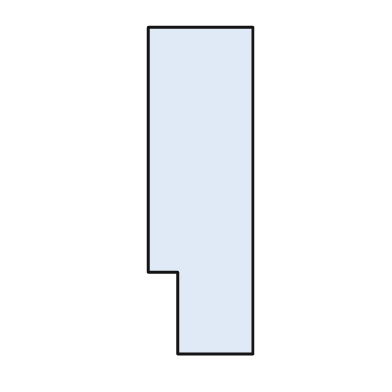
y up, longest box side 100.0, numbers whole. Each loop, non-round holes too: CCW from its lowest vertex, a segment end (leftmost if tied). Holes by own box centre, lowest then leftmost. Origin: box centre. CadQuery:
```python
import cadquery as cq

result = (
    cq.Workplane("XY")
    .moveTo(-7.0, -50.0)
    .lineTo(16.0, -50.0)
    .lineTo(16.0, 50.0)
    .lineTo(-16.0, 50.0)
    .lineTo(-16.0, -25.0)
    .lineTo(-7.0, -25.0)
    .close()
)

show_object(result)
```